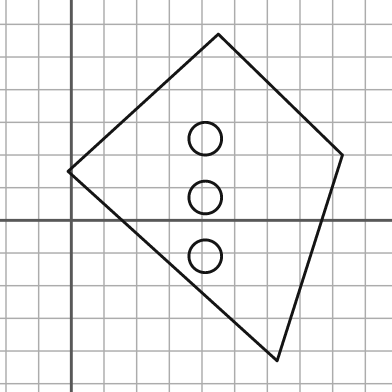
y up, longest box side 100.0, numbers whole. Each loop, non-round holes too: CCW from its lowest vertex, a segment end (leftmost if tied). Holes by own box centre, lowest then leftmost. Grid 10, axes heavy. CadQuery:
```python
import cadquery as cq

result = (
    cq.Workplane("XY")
    .moveTo(63.0, -43.0)
    .lineTo(83.0, 20.0)
    .lineTo(45.0, 57.0)
    .lineTo(-1.0, 15.0)
    .close()
    .moveTo(41.0, -11.0)
    .circle(5.0)
    .moveTo(41.0, 7.0)
    .circle(5.0)
    .moveTo(41.0, 25.0)
    .circle(5.0)
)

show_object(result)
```